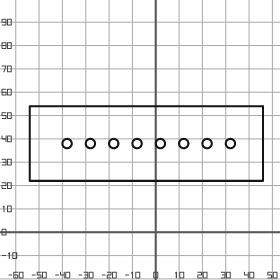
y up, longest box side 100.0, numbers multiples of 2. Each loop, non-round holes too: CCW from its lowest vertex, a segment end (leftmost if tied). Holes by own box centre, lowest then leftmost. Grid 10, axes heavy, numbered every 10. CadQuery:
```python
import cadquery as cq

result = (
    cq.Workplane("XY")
    .moveTo(-54.0, 22.0)
    .lineTo(46.0, 22.0)
    .lineTo(46.0, 54.0)
    .lineTo(-54.0, 54.0)
    .close()
    .moveTo(-38.0, 38.0)
    .circle(2.0)
    .moveTo(-28.0, 38.0)
    .circle(2.0)
    .moveTo(-18.0, 38.0)
    .circle(2.0)
    .moveTo(-8.0, 38.0)
    .circle(2.0)
    .moveTo(2.0, 38.0)
    .circle(2.0)
    .moveTo(12.0, 38.0)
    .circle(2.0)
    .moveTo(22.0, 38.0)
    .circle(2.0)
    .moveTo(32.0, 38.0)
    .circle(2.0)
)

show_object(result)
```